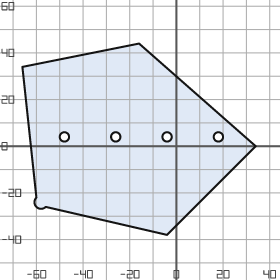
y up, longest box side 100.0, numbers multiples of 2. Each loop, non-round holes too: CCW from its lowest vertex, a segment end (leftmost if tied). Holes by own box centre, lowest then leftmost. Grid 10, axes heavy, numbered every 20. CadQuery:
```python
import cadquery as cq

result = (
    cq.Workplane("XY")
    .moveTo(-4.0, -38.0)
    .lineTo(34.0, 0.0)
    .lineTo(-16.0, 44.0)
    .lineTo(-66.0, 34.0)
    .lineTo(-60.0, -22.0)
    .threePointArc((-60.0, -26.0), (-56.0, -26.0))
    .close()
    .moveTo(-48.0, 4.0)
    .circle(2.0)
    .moveTo(-26.0, 4.0)
    .circle(2.0)
    .moveTo(-4.0, 4.0)
    .circle(2.0)
    .moveTo(18.0, 4.0)
    .circle(2.0)
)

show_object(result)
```